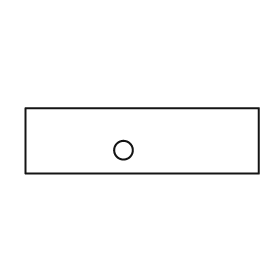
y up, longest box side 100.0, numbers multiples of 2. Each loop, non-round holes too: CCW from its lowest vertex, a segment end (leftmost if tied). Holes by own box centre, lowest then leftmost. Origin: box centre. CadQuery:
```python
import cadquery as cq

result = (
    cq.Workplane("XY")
    .moveTo(-50.0, -14.0)
    .lineTo(50.0, -14.0)
    .lineTo(50.0, 14.0)
    .lineTo(-50.0, 14.0)
    .close()
    .moveTo(-8.0, -4.0)
    .circle(4.0)
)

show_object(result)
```